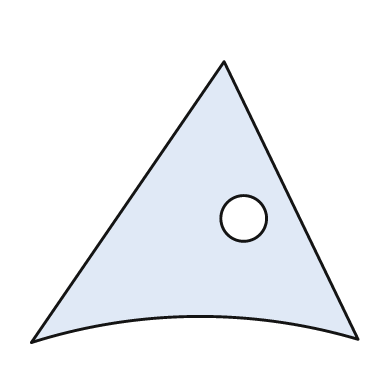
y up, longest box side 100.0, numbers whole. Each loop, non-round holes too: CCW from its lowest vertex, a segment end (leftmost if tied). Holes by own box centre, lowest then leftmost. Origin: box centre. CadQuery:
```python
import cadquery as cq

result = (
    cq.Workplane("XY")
    .moveTo(-50.0, -43.0)
    .threePointArc((0.0, -35.0), (50.0, -42.0))
    .lineTo(9.0, 43.0)
    .close()
    .moveTo(15.0, -5.0)
    .circle(7.0)
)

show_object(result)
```